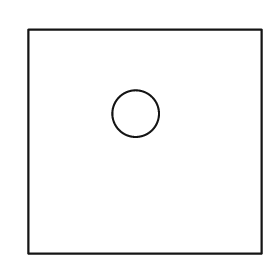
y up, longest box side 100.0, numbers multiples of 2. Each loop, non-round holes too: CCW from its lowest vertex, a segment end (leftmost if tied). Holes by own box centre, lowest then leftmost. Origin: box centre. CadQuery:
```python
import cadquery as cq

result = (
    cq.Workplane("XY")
    .moveTo(-50.0, -48.0)
    .lineTo(50.0, -48.0)
    .lineTo(50.0, 48.0)
    .lineTo(-50.0, 48.0)
    .close()
    .moveTo(-4.0, 12.0)
    .circle(10.0)
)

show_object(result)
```